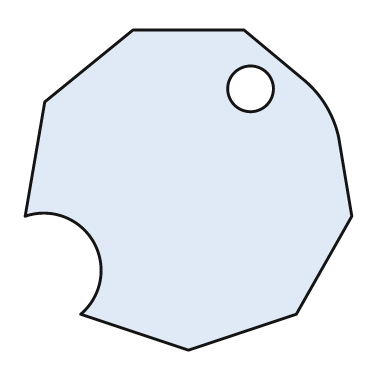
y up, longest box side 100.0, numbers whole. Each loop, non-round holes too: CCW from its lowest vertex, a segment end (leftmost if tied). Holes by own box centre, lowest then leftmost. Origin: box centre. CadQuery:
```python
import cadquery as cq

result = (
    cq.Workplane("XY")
    .moveTo(0.0, -49.0)
    .lineTo(33.0, -38.0)
    .lineTo(50.0, -8.0)
    .lineTo(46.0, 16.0)
    .threePointArc((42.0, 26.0), (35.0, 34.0))
    .lineTo(17.0, 49.0)
    .lineTo(-17.0, 49.0)
    .lineTo(-44.0, 27.0)
    .lineTo(-50.0, -8.0)
    .threePointArc((-29.0, -16.0), (-33.0, -38.0))
    .close()
    .moveTo(19.0, 31.0)
    .circle(7.0)
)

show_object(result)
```